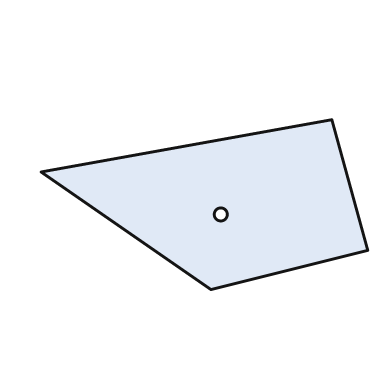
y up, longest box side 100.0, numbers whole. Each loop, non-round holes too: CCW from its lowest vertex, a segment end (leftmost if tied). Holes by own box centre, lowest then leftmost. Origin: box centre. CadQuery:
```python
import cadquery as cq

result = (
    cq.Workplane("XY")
    .moveTo(2.0, -26.0)
    .lineTo(50.0, -14.0)
    .lineTo(39.0, 26.0)
    .lineTo(-50.0, 10.0)
    .close()
    .moveTo(5.0, -3.0)
    .circle(2.0)
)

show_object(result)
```